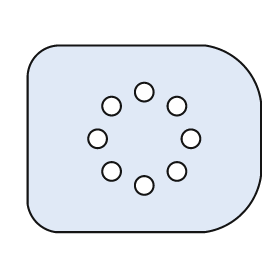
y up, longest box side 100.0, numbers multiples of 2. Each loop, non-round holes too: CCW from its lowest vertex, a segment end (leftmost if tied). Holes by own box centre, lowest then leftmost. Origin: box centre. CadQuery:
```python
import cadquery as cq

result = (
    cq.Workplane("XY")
    .moveTo(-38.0, -40.0)
    .lineTo(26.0, -40.0)
    .threePointArc((42.0, -32.0), (50.0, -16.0))
    .lineTo(50.0, 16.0)
    .threePointArc((42.0, 32.0), (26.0, 40.0))
    .lineTo(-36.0, 40.0)
    .threePointArc((-46.0, 36.0), (-50.0, 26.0))
    .lineTo(-50.0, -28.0)
    .threePointArc((-46.0, -36.0), (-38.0, -40.0))
    .close()
    .moveTo(0.0, -20.0)
    .circle(4.0)
    .moveTo(-14.0, -14.0)
    .circle(4.0)
    .moveTo(14.0, -14.0)
    .circle(4.0)
    .moveTo(-20.0, 0.0)
    .circle(4.0)
    .moveTo(20.0, 0.0)
    .circle(4.0)
    .moveTo(-14.0, 14.0)
    .circle(4.0)
    .moveTo(14.0, 14.0)
    .circle(4.0)
    .moveTo(0.0, 20.0)
    .circle(4.0)
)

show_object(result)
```